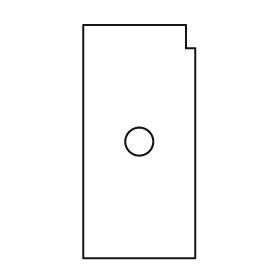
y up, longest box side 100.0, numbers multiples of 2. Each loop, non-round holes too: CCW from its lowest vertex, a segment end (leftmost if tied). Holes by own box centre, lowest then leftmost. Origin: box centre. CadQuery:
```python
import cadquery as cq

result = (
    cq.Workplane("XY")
    .moveTo(-24.0, -50.0)
    .lineTo(24.0, -50.0)
    .lineTo(24.0, 40.0)
    .lineTo(20.0, 40.0)
    .lineTo(20.0, 50.0)
    .lineTo(-24.0, 50.0)
    .close()
    .moveTo(0.0, 0.0)
    .circle(6.0)
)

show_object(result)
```